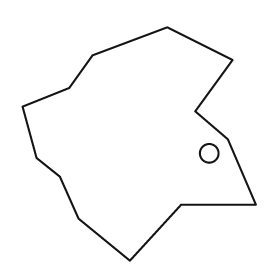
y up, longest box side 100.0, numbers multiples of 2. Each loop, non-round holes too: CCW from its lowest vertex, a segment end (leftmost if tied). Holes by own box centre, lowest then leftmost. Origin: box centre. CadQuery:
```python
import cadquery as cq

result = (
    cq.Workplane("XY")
    .moveTo(-4.0, -50.0)
    .lineTo(18.0, -26.0)
    .lineTo(50.0, -26.0)
    .lineTo(38.0, 2.0)
    .lineTo(24.0, 14.0)
    .lineTo(40.0, 36.0)
    .lineTo(12.0, 50.0)
    .lineTo(-20.0, 38.0)
    .lineTo(-30.0, 24.0)
    .lineTo(-50.0, 16.0)
    .lineTo(-44.0, -6.0)
    .lineTo(-34.0, -14.0)
    .lineTo(-26.0, -32.0)
    .close()
    .moveTo(30.0, -4.0)
    .circle(4.0)
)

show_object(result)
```